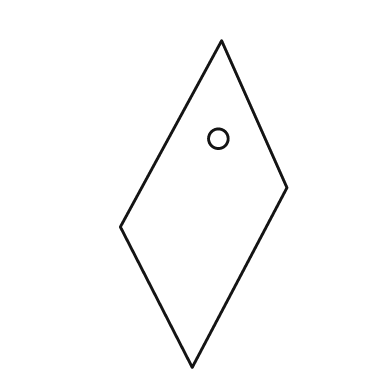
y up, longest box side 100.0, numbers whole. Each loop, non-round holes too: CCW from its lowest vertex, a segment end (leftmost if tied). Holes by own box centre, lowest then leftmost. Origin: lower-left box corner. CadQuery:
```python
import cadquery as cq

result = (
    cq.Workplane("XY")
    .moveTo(22.0, 0.0)
    .lineTo(51.0, 55.0)
    .lineTo(31.0, 100.0)
    .lineTo(0.0, 43.0)
    .close()
    .moveTo(30.0, 70.0)
    .circle(3.0)
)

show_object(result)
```